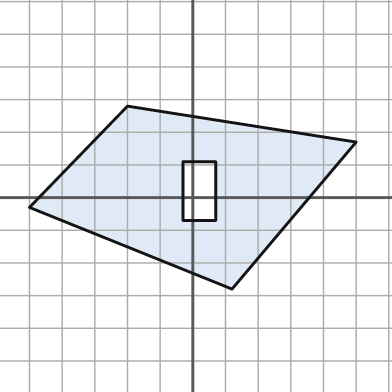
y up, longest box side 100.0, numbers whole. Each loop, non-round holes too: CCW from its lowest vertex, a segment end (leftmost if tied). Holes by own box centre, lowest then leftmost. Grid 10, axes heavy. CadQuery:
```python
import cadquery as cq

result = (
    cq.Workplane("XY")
    .moveTo(12.0, -28.0)
    .lineTo(50.0, 17.0)
    .lineTo(-20.0, 28.0)
    .lineTo(-50.0, -3.0)
    .close()
    .moveTo(-3.0, -7.0)
    .lineTo(7.0, -7.0)
    .lineTo(7.0, 11.0)
    .lineTo(-3.0, 11.0)
    .close()
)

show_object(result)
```